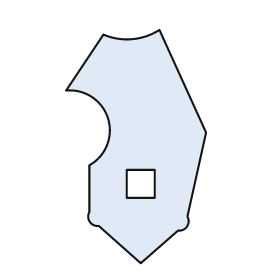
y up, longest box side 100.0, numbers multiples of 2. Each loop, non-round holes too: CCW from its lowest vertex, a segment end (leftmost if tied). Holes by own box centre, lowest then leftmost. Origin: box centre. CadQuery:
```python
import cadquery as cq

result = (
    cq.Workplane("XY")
    .moveTo(2.0, -50.0)
    .lineTo(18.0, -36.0)
    .threePointArc((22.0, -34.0), (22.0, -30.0))
    .lineTo(30.0, 6.0)
    .lineTo(10.0, 50.0)
    .threePointArc((-2.0, 46.0), (-14.0, 48.0))
    .lineTo(-30.0, 24.0)
    .threePointArc((-12.0, 12.0), (-20.0, -8.0))
    .lineTo(-20.0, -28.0)
    .threePointArc((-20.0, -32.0), (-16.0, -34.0))
    .close()
    .moveTo(-4.0, -22.0)
    .lineTo(8.0, -22.0)
    .lineTo(8.0, -10.0)
    .lineTo(-4.0, -10.0)
    .close()
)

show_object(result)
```